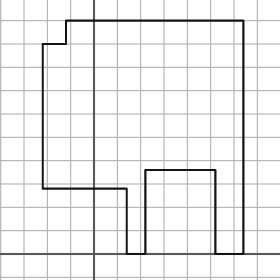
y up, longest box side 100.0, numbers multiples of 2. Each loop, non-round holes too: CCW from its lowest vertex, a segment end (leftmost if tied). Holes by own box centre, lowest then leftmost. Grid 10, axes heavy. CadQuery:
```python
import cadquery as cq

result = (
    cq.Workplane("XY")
    .moveTo(14.0, 0.0)
    .lineTo(22.0, 0.0)
    .lineTo(22.0, 36.0)
    .lineTo(52.0, 36.0)
    .lineTo(52.0, 0.0)
    .lineTo(64.0, 0.0)
    .lineTo(64.0, 100.0)
    .lineTo(-12.0, 100.0)
    .lineTo(-12.0, 90.0)
    .lineTo(-22.0, 90.0)
    .lineTo(-22.0, 28.0)
    .lineTo(14.0, 28.0)
    .close()
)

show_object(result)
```